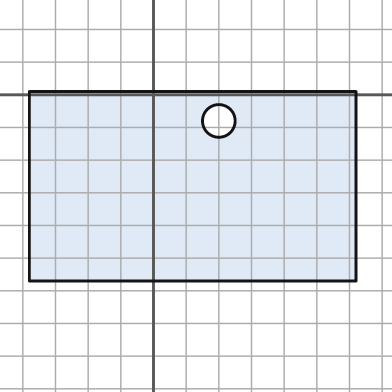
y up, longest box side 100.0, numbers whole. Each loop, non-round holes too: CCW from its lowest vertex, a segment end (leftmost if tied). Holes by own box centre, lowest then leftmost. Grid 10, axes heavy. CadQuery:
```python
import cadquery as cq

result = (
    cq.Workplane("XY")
    .moveTo(-38.0, -57.0)
    .lineTo(62.0, -57.0)
    .lineTo(62.0, 1.0)
    .lineTo(-38.0, 1.0)
    .close()
    .moveTo(20.0, -8.0)
    .circle(5.0)
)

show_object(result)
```